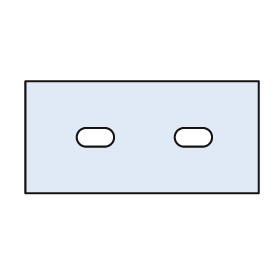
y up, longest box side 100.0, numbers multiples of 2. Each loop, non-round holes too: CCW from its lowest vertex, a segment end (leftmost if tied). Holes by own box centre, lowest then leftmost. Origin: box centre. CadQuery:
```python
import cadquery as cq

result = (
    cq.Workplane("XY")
    .moveTo(-50.0, -24.0)
    .lineTo(50.0, -24.0)
    .lineTo(50.0, 24.0)
    .lineTo(-50.0, 24.0)
    .close()
    .moveTo(-24.0, -4.0)
    .lineTo(-16.0, -4.0)
    .threePointArc((-12.0, 0.0), (-16.0, 4.0))
    .lineTo(-24.0, 4.0)
    .threePointArc((-28.0, 0.0), (-24.0, -4.0))
    .close()
    .moveTo(18.0, -4.0)
    .lineTo(26.0, -4.0)
    .threePointArc((30.0, 0.0), (26.0, 4.0))
    .lineTo(18.0, 4.0)
    .threePointArc((14.0, 0.0), (18.0, -4.0))
    .close()
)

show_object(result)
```